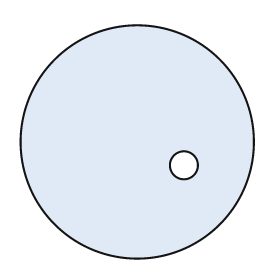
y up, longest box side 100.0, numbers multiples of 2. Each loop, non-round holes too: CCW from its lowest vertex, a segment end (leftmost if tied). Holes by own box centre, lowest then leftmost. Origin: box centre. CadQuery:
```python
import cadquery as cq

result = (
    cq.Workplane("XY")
    .moveTo(0.0, 0.0)
    .circle(50.0)
    .moveTo(20.0, -10.0)
    .circle(6.0)
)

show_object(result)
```